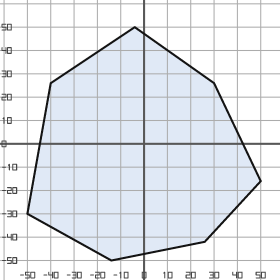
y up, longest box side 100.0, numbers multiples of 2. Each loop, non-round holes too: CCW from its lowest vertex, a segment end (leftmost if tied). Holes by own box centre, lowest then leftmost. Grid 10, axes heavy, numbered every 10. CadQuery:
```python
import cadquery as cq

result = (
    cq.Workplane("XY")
    .moveTo(-14.0, -50.0)
    .lineTo(26.0, -42.0)
    .lineTo(50.0, -16.0)
    .lineTo(30.0, 26.0)
    .lineTo(-4.0, 50.0)
    .lineTo(-40.0, 26.0)
    .lineTo(-50.0, -30.0)
    .close()
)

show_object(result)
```